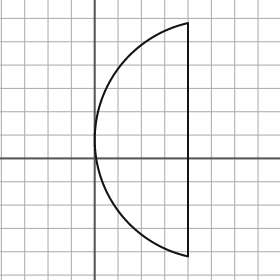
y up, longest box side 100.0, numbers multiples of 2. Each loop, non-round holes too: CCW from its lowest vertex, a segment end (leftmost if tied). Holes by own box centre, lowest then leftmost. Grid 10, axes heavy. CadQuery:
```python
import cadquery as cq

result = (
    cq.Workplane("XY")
    .moveTo(40.0, -42.0)
    .lineTo(40.0, 58.0)
    .threePointArc((0.0, 8.0), (40.0, -42.0))
    .close()
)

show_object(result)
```